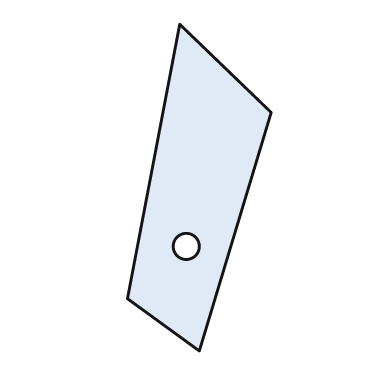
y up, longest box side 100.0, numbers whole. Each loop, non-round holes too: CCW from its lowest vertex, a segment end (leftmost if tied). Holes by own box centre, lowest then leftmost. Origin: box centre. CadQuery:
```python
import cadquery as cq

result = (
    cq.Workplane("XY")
    .moveTo(0.0, -50.0)
    .lineTo(22.0, 23.0)
    .lineTo(-6.0, 50.0)
    .lineTo(-22.0, -34.0)
    .close()
    .moveTo(-4.0, -18.0)
    .circle(4.0)
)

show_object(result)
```